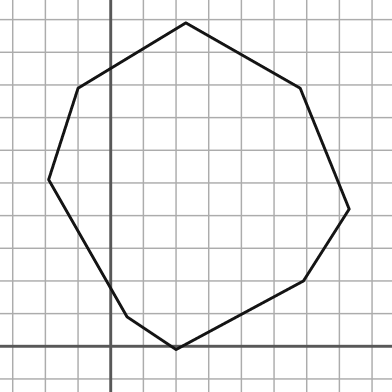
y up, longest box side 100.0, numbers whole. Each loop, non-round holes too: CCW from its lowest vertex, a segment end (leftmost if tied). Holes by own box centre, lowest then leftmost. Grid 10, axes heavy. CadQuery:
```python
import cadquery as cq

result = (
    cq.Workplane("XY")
    .moveTo(20.0, -1.0)
    .lineTo(59.0, 20.0)
    .lineTo(73.0, 42.0)
    .lineTo(58.0, 79.0)
    .lineTo(23.0, 99.0)
    .lineTo(-10.0, 79.0)
    .lineTo(-19.0, 51.0)
    .lineTo(5.0, 9.0)
    .close()
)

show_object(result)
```